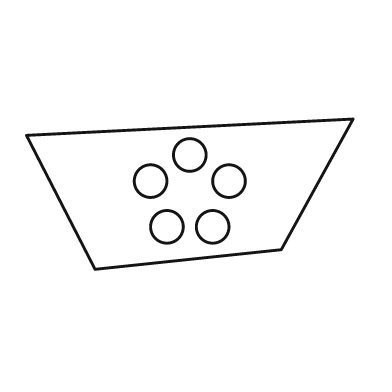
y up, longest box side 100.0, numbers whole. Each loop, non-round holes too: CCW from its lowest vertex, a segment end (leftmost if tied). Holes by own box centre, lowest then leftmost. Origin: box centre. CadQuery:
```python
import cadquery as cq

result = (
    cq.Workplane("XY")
    .moveTo(-29.0, -23.0)
    .lineTo(28.0, -17.0)
    .lineTo(50.0, 23.0)
    .lineTo(-50.0, 18.0)
    .close()
    .moveTo(-7.0, -10.0)
    .circle(5.0)
    .moveTo(7.0, -10.0)
    .circle(5.0)
    .moveTo(-12.0, 4.0)
    .circle(5.0)
    .moveTo(12.0, 4.0)
    .circle(5.0)
    .moveTo(0.0, 12.0)
    .circle(5.0)
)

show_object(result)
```